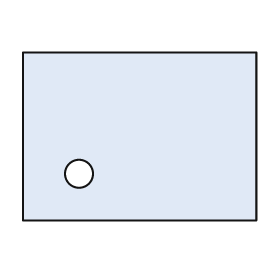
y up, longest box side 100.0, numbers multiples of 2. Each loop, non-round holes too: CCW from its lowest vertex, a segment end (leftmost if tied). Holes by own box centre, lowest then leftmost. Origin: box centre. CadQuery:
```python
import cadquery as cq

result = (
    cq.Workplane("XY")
    .moveTo(-50.0, -36.0)
    .lineTo(50.0, -36.0)
    .lineTo(50.0, 36.0)
    .lineTo(-50.0, 36.0)
    .close()
    .moveTo(-26.0, -16.0)
    .circle(6.0)
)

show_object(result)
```